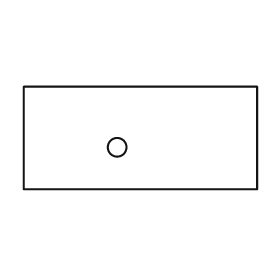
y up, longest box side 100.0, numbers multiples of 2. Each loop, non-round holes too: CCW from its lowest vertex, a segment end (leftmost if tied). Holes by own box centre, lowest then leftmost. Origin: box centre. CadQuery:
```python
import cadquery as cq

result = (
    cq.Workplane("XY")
    .moveTo(-50.0, -22.0)
    .lineTo(50.0, -22.0)
    .lineTo(50.0, 22.0)
    .lineTo(-50.0, 22.0)
    .close()
    .moveTo(-10.0, -4.0)
    .circle(4.0)
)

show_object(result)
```